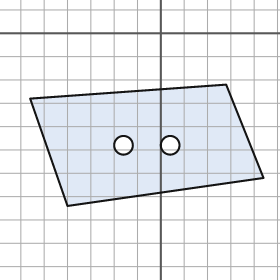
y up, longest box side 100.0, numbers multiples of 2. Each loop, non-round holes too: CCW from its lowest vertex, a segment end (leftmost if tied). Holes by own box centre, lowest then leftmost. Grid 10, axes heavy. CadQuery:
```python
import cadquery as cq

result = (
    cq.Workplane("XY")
    .moveTo(-40.0, -74.0)
    .lineTo(44.0, -62.0)
    .lineTo(28.0, -22.0)
    .lineTo(-56.0, -28.0)
    .close()
    .moveTo(-16.0, -48.0)
    .circle(4.0)
    .moveTo(4.0, -48.0)
    .circle(4.0)
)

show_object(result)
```